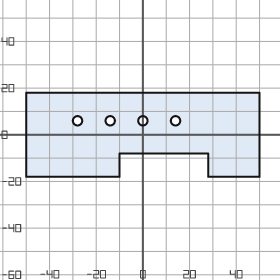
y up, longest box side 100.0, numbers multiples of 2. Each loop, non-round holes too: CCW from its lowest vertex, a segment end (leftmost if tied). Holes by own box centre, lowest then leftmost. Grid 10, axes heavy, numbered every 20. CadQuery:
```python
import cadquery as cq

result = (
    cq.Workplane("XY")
    .moveTo(-50.0, -18.0)
    .lineTo(-10.0, -18.0)
    .lineTo(-10.0, -8.0)
    .lineTo(28.0, -8.0)
    .lineTo(28.0, -18.0)
    .lineTo(50.0, -18.0)
    .lineTo(50.0, 18.0)
    .lineTo(-50.0, 18.0)
    .close()
    .moveTo(-28.0, 6.0)
    .circle(2.0)
    .moveTo(-14.0, 6.0)
    .circle(2.0)
    .moveTo(0.0, 6.0)
    .circle(2.0)
    .moveTo(14.0, 6.0)
    .circle(2.0)
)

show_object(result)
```